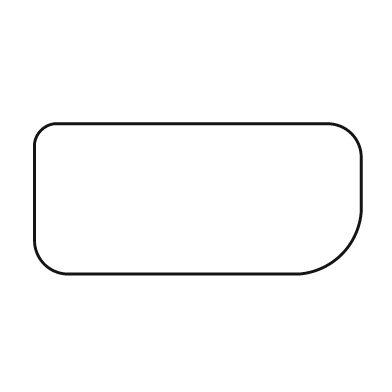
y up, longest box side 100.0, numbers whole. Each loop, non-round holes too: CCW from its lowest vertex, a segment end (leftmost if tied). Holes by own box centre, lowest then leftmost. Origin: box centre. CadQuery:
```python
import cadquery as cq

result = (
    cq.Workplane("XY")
    .moveTo(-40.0, -23.0)
    .lineTo(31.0, -23.0)
    .threePointArc((44.0, -17.0), (50.0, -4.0))
    .lineTo(50.0, 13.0)
    .threePointArc((47.0, 20.0), (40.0, 23.0))
    .lineTo(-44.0, 23.0)
    .threePointArc((-48.0, 21.0), (-50.0, 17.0))
    .lineTo(-50.0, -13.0)
    .threePointArc((-47.0, -20.0), (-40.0, -23.0))
    .close()
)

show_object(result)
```